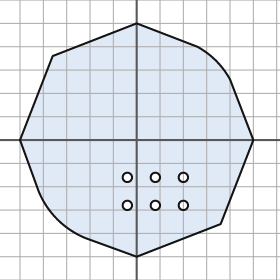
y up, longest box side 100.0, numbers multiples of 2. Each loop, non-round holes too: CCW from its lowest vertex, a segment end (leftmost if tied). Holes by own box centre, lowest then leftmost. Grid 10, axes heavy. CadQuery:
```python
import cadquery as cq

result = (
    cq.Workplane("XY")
    .moveTo(0.0, -50.0)
    .lineTo(36.0, -36.0)
    .lineTo(50.0, 0.0)
    .lineTo(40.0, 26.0)
    .threePointArc((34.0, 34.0), (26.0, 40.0))
    .lineTo(0.0, 50.0)
    .lineTo(-36.0, 36.0)
    .lineTo(-50.0, 0.0)
    .lineTo(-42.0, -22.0)
    .threePointArc((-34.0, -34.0), (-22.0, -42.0))
    .close()
    .moveTo(-4.0, -28.0)
    .circle(2.0)
    .moveTo(8.0, -28.0)
    .circle(2.0)
    .moveTo(20.0, -28.0)
    .circle(2.0)
    .moveTo(-4.0, -16.0)
    .circle(2.0)
    .moveTo(8.0, -16.0)
    .circle(2.0)
    .moveTo(20.0, -16.0)
    .circle(2.0)
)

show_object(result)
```